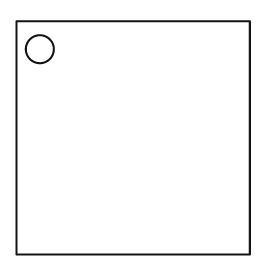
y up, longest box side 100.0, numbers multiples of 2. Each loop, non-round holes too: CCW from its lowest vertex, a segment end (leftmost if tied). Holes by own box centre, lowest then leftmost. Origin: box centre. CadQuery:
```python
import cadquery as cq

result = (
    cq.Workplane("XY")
    .moveTo(-50.0, -50.0)
    .lineTo(50.0, -50.0)
    .lineTo(50.0, 50.0)
    .lineTo(-50.0, 50.0)
    .close()
    .moveTo(-40.0, 38.0)
    .circle(6.0)
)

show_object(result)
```